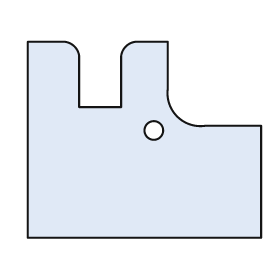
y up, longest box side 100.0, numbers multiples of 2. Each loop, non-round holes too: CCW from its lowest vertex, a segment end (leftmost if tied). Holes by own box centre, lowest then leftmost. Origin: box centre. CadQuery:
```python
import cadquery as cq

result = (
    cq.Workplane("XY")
    .moveTo(-50.0, -42.0)
    .lineTo(50.0, -42.0)
    .lineTo(50.0, 6.0)
    .lineTo(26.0, 6.0)
    .threePointArc((14.0, 10.0), (10.0, 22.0))
    .lineTo(10.0, 42.0)
    .lineTo(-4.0, 42.0)
    .threePointArc((-8.0, 40.0), (-10.0, 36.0))
    .lineTo(-10.0, 14.0)
    .lineTo(-28.0, 14.0)
    .lineTo(-28.0, 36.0)
    .threePointArc((-30.0, 40.0), (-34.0, 42.0))
    .lineTo(-50.0, 42.0)
    .close()
    .moveTo(4.0, 4.0)
    .circle(4.0)
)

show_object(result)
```